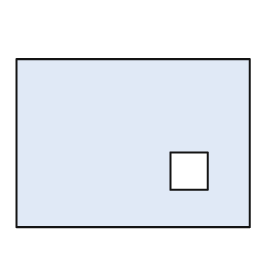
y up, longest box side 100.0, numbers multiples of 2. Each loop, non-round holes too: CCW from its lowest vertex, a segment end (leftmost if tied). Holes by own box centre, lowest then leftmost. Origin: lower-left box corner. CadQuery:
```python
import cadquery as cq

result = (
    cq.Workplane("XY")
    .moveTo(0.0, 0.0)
    .lineTo(100.0, 0.0)
    .lineTo(100.0, 72.0)
    .lineTo(0.0, 72.0)
    .close()
    .moveTo(66.0, 16.0)
    .lineTo(82.0, 16.0)
    .lineTo(82.0, 32.0)
    .lineTo(66.0, 32.0)
    .close()
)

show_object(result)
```